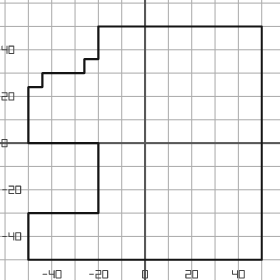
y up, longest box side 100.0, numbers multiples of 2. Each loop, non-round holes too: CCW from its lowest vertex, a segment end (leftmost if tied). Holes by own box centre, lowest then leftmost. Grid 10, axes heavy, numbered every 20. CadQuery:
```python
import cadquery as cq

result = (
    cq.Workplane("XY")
    .moveTo(-50.0, -50.0)
    .lineTo(50.0, -50.0)
    .lineTo(50.0, 50.0)
    .lineTo(-20.0, 50.0)
    .lineTo(-20.0, 36.0)
    .lineTo(-26.0, 36.0)
    .lineTo(-26.0, 30.0)
    .lineTo(-44.0, 30.0)
    .lineTo(-44.0, 24.0)
    .lineTo(-50.0, 24.0)
    .lineTo(-50.0, 0.0)
    .lineTo(-20.0, 0.0)
    .lineTo(-20.0, -30.0)
    .lineTo(-50.0, -30.0)
    .close()
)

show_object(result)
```